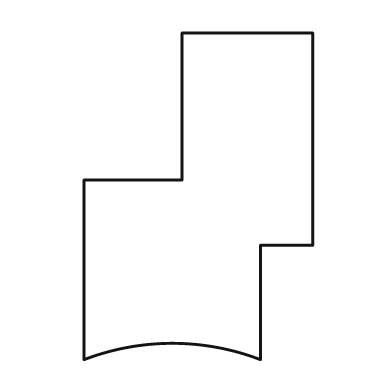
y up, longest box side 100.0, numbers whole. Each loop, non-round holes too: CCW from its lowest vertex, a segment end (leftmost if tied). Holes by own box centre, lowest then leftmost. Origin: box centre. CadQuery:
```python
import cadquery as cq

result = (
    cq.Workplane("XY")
    .moveTo(-35.0, -50.0)
    .threePointArc((-8.0, -45.0), (19.0, -50.0))
    .lineTo(19.0, -15.0)
    .lineTo(35.0, -15.0)
    .lineTo(35.0, 50.0)
    .lineTo(-5.0, 50.0)
    .lineTo(-5.0, 5.0)
    .lineTo(-35.0, 5.0)
    .close()
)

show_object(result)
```